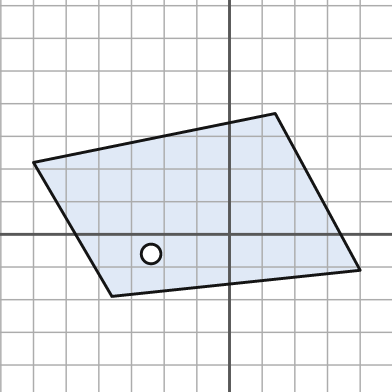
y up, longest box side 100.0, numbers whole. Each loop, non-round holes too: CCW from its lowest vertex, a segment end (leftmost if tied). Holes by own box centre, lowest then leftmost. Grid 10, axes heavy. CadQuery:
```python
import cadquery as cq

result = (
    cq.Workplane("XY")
    .moveTo(-36.0, -19.0)
    .lineTo(40.0, -11.0)
    .lineTo(14.0, 37.0)
    .lineTo(-60.0, 22.0)
    .close()
    .moveTo(-24.0, -6.0)
    .circle(3.0)
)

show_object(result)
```